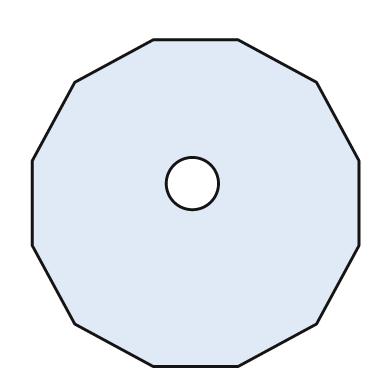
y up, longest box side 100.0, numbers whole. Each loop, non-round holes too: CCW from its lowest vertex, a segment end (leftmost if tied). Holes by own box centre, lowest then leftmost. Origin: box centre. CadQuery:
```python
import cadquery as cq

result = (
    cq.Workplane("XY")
    .moveTo(-13.0, -50.0)
    .lineTo(13.0, -50.0)
    .lineTo(37.0, -37.0)
    .lineTo(50.0, -13.0)
    .lineTo(50.0, 13.0)
    .lineTo(37.0, 37.0)
    .lineTo(13.0, 50.0)
    .lineTo(-13.0, 50.0)
    .lineTo(-37.0, 37.0)
    .lineTo(-50.0, 13.0)
    .lineTo(-50.0, -13.0)
    .lineTo(-37.0, -37.0)
    .close()
    .moveTo(-1.0, 6.0)
    .circle(8.0)
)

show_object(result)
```